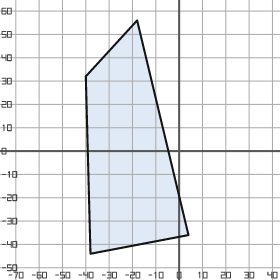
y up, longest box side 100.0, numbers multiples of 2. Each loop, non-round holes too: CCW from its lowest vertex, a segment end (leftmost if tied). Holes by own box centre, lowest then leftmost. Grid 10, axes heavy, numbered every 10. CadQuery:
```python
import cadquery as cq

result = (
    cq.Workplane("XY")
    .moveTo(-38.0, -44.0)
    .lineTo(4.0, -36.0)
    .lineTo(-18.0, 56.0)
    .lineTo(-40.0, 32.0)
    .close()
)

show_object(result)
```